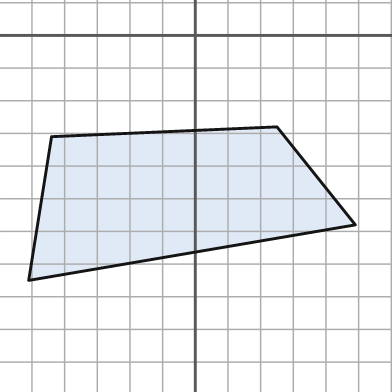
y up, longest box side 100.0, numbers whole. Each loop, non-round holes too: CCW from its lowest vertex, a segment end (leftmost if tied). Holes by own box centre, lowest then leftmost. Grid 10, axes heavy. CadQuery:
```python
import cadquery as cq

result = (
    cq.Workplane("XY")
    .moveTo(-51.0, -75.0)
    .lineTo(49.0, -58.0)
    .lineTo(25.0, -28.0)
    .lineTo(-44.0, -31.0)
    .close()
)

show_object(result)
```